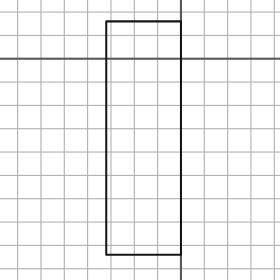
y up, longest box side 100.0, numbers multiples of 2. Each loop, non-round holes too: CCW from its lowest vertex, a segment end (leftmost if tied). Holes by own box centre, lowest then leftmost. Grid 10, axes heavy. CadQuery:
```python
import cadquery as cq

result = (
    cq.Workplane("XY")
    .moveTo(-32.0, -84.0)
    .lineTo(0.0, -84.0)
    .lineTo(0.0, 16.0)
    .lineTo(-32.0, 16.0)
    .close()
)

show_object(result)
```